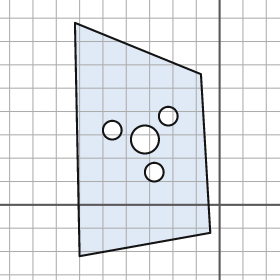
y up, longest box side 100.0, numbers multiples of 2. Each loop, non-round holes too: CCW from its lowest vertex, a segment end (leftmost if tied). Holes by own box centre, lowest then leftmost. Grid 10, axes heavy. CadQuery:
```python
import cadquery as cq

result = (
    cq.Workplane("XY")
    .moveTo(-60.0, -22.0)
    .lineTo(-4.0, -12.0)
    .lineTo(-8.0, 56.0)
    .lineTo(-62.0, 78.0)
    .close()
    .moveTo(-28.0, 14.0)
    .circle(4.0)
    .moveTo(-32.0, 28.0)
    .circle(6.0)
    .moveTo(-46.0, 32.0)
    .circle(4.0)
    .moveTo(-22.0, 38.0)
    .circle(4.0)
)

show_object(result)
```